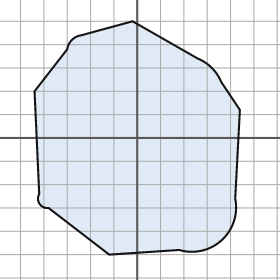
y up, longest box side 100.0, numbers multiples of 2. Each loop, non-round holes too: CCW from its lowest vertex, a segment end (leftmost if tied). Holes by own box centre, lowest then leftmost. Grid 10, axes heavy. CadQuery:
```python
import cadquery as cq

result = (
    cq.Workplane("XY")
    .moveTo(-12.0, -50.0)
    .lineTo(18.0, -48.0)
    .threePointArc((36.0, -44.0), (42.0, -26.0))
    .lineTo(44.0, 12.0)
    .lineTo(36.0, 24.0)
    .threePointArc((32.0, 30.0), (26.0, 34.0))
    .lineTo(-2.0, 50.0)
    .lineTo(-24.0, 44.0)
    .threePointArc((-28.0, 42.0), (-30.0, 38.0))
    .lineTo(-44.0, 20.0)
    .lineTo(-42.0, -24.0)
    .threePointArc((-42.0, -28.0), (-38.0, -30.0))
    .close()
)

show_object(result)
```